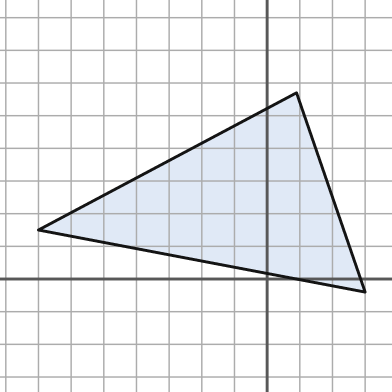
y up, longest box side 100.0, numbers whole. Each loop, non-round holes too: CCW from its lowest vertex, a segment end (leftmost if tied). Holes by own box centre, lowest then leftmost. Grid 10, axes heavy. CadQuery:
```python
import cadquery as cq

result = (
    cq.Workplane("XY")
    .moveTo(30.0, -4.0)
    .lineTo(9.0, 57.0)
    .lineTo(-70.0, 15.0)
    .close()
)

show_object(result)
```